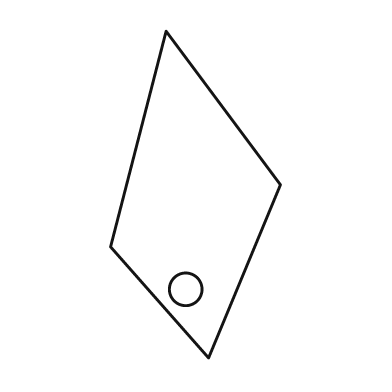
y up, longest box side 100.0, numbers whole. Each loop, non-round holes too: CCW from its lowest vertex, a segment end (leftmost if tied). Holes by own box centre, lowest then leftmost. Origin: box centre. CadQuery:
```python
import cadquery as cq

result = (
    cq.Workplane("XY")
    .moveTo(4.0, -50.0)
    .lineTo(26.0, 3.0)
    .lineTo(-9.0, 50.0)
    .lineTo(-26.0, -16.0)
    .close()
    .moveTo(-3.0, -29.0)
    .circle(5.0)
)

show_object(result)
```